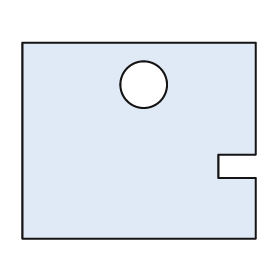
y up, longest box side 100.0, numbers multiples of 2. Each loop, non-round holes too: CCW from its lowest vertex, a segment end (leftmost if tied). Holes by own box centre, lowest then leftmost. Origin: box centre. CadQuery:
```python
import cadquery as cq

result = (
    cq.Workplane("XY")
    .moveTo(-50.0, -42.0)
    .lineTo(50.0, -42.0)
    .lineTo(50.0, -16.0)
    .lineTo(34.0, -16.0)
    .lineTo(34.0, -6.0)
    .lineTo(50.0, -6.0)
    .lineTo(50.0, 42.0)
    .lineTo(-50.0, 42.0)
    .close()
    .moveTo(2.0, 24.0)
    .circle(10.0)
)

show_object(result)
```